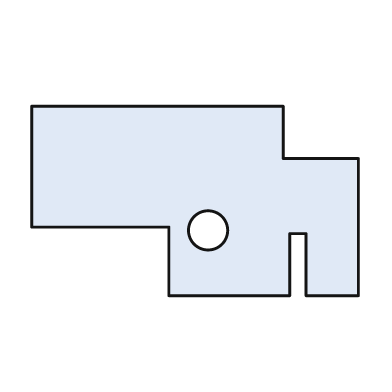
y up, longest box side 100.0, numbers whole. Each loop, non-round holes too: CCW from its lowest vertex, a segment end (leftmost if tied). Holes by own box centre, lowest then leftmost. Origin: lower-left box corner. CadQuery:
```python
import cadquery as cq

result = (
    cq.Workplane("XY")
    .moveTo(42.0, 0.0)
    .lineTo(79.0, 0.0)
    .lineTo(79.0, 19.0)
    .lineTo(84.0, 19.0)
    .lineTo(84.0, 0.0)
    .lineTo(100.0, 0.0)
    .lineTo(100.0, 42.0)
    .lineTo(77.0, 42.0)
    .lineTo(77.0, 58.0)
    .lineTo(0.0, 58.0)
    .lineTo(0.0, 21.0)
    .lineTo(42.0, 21.0)
    .close()
    .moveTo(54.0, 20.0)
    .circle(6.0)
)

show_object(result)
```